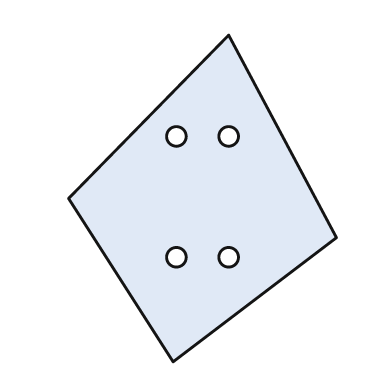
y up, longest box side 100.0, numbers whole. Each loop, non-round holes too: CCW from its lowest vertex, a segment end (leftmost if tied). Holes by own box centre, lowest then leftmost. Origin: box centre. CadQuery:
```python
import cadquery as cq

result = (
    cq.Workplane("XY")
    .moveTo(-9.0, -50.0)
    .lineTo(41.0, -12.0)
    .lineTo(8.0, 50.0)
    .lineTo(-41.0, 0.0)
    .close()
    .moveTo(-8.0, -18.0)
    .circle(3.0)
    .moveTo(8.0, -18.0)
    .circle(3.0)
    .moveTo(-8.0, 19.0)
    .circle(3.0)
    .moveTo(8.0, 19.0)
    .circle(3.0)
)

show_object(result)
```